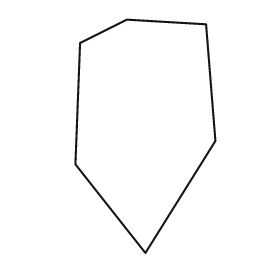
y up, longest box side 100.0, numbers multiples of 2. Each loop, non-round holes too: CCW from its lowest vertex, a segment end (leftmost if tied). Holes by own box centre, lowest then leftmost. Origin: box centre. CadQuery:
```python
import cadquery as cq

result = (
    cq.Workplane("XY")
    .moveTo(0.0, -50.0)
    .lineTo(30.0, -2.0)
    .lineTo(26.0, 48.0)
    .lineTo(-8.0, 50.0)
    .lineTo(-28.0, 40.0)
    .lineTo(-30.0, -12.0)
    .close()
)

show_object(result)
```